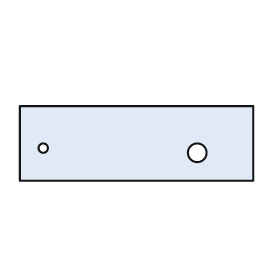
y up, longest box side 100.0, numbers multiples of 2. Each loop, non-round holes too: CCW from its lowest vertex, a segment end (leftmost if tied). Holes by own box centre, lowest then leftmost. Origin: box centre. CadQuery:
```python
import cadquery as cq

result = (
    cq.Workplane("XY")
    .moveTo(-50.0, -16.0)
    .lineTo(50.0, -16.0)
    .lineTo(50.0, 16.0)
    .lineTo(-50.0, 16.0)
    .close()
    .moveTo(26.0, -4.0)
    .circle(4.0)
    .moveTo(-40.0, -2.0)
    .circle(2.0)
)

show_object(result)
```